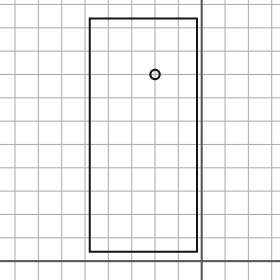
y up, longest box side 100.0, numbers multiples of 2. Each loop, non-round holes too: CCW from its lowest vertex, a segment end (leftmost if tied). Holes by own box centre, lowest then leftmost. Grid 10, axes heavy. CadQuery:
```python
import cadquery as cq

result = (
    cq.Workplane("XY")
    .moveTo(-48.0, 4.0)
    .lineTo(-2.0, 4.0)
    .lineTo(-2.0, 104.0)
    .lineTo(-48.0, 104.0)
    .close()
    .moveTo(-20.0, 80.0)
    .circle(2.0)
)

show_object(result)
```